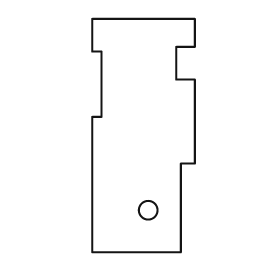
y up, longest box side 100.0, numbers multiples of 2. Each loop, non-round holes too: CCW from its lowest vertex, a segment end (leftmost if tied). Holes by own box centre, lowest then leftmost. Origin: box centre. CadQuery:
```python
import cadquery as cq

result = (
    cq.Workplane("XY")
    .moveTo(-22.0, -50.0)
    .lineTo(16.0, -50.0)
    .lineTo(16.0, -12.0)
    .lineTo(22.0, -12.0)
    .lineTo(22.0, 24.0)
    .lineTo(14.0, 24.0)
    .lineTo(14.0, 38.0)
    .lineTo(22.0, 38.0)
    .lineTo(22.0, 50.0)
    .lineTo(-22.0, 50.0)
    .lineTo(-22.0, 36.0)
    .lineTo(-18.0, 36.0)
    .lineTo(-18.0, 8.0)
    .lineTo(-22.0, 8.0)
    .close()
    .moveTo(2.0, -32.0)
    .circle(4.0)
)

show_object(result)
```